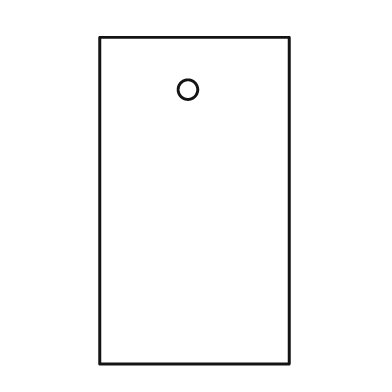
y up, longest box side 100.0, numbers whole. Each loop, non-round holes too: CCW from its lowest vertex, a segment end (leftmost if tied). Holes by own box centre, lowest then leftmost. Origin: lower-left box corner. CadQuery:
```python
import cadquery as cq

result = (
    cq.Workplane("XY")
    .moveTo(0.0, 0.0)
    .lineTo(58.0, 0.0)
    .lineTo(58.0, 100.0)
    .lineTo(0.0, 100.0)
    .close()
    .moveTo(27.0, 84.0)
    .circle(3.0)
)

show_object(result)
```